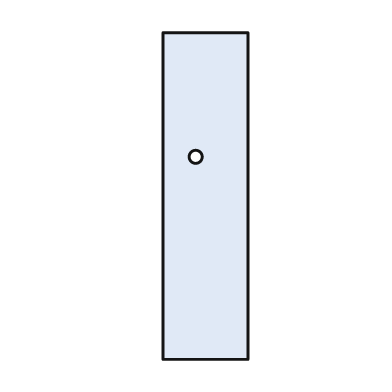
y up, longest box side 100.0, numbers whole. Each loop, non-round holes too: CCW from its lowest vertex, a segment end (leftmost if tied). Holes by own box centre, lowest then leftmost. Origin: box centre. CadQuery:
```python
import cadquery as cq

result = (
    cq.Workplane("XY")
    .moveTo(-13.0, -50.0)
    .lineTo(13.0, -50.0)
    .lineTo(13.0, 50.0)
    .lineTo(-13.0, 50.0)
    .close()
    .moveTo(-3.0, 12.0)
    .circle(2.0)
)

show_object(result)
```